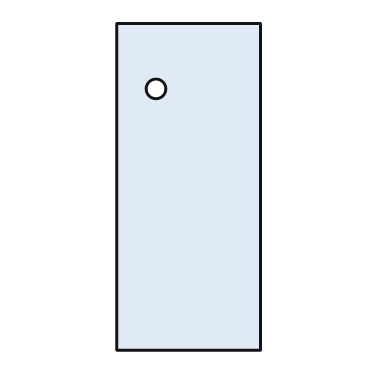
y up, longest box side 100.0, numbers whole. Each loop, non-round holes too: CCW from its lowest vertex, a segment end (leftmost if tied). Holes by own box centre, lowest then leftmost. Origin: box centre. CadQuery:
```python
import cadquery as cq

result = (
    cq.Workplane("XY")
    .moveTo(-22.0, -50.0)
    .lineTo(22.0, -50.0)
    .lineTo(22.0, 50.0)
    .lineTo(-22.0, 50.0)
    .close()
    .moveTo(-10.0, 30.0)
    .circle(3.0)
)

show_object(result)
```